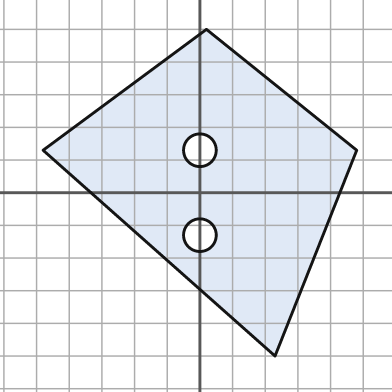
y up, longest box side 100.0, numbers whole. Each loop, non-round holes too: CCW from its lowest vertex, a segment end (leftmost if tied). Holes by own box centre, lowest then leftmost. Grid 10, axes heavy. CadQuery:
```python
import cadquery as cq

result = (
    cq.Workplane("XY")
    .moveTo(23.0, -50.0)
    .lineTo(48.0, 13.0)
    .lineTo(2.0, 50.0)
    .lineTo(-48.0, 13.0)
    .close()
    .moveTo(0.0, -13.0)
    .circle(5.0)
    .moveTo(0.0, 13.0)
    .circle(5.0)
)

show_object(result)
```